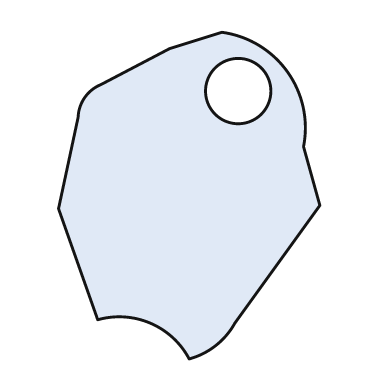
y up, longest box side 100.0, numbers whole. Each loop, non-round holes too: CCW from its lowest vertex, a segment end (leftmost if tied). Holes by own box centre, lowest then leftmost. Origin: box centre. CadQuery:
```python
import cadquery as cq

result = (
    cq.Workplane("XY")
    .moveTo(0.0, -50.0)
    .threePointArc((8.0, -46.0), (14.0, -39.0))
    .lineTo(40.0, -3.0)
    .lineTo(35.0, 15.0)
    .threePointArc((30.0, 38.0), (10.0, 50.0))
    .lineTo(-6.0, 45.0)
    .lineTo(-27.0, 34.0)
    .threePointArc((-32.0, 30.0), (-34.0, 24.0))
    .lineTo(-40.0, -4.0)
    .lineTo(-28.0, -38.0)
    .threePointArc((-12.0, -39.0), (0.0, -50.0))
    .close()
    .moveTo(15.0, 32.0)
    .circle(10.0)
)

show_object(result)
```